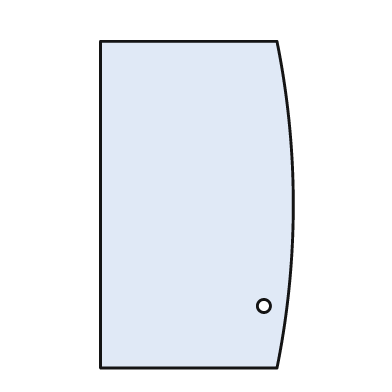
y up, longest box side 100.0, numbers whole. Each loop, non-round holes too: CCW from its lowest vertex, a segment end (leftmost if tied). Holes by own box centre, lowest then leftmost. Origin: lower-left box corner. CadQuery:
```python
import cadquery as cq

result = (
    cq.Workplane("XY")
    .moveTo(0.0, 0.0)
    .lineTo(54.0, 0.0)
    .threePointArc((59.0, 50.0), (54.0, 100.0))
    .lineTo(0.0, 100.0)
    .close()
    .moveTo(50.0, 19.0)
    .circle(2.0)
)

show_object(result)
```